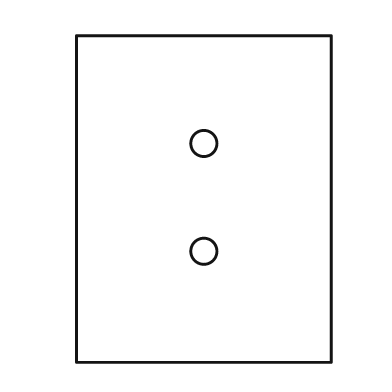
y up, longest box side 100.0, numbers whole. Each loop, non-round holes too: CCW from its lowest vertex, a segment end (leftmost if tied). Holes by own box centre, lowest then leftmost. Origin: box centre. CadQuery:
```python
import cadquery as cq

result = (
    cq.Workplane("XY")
    .moveTo(-39.0, -50.0)
    .lineTo(39.0, -50.0)
    .lineTo(39.0, 50.0)
    .lineTo(-39.0, 50.0)
    .close()
    .moveTo(0.0, -16.0)
    .circle(4.0)
    .moveTo(0.0, 17.0)
    .circle(4.0)
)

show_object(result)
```